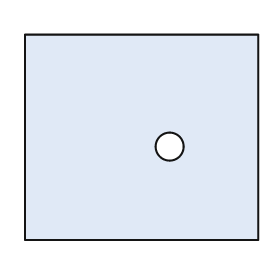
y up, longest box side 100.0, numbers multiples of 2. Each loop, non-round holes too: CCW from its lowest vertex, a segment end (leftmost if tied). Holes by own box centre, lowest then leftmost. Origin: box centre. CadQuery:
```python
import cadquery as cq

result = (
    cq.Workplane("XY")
    .moveTo(-50.0, -44.0)
    .lineTo(50.0, -44.0)
    .lineTo(50.0, 44.0)
    .lineTo(-50.0, 44.0)
    .close()
    .moveTo(12.0, -4.0)
    .circle(6.0)
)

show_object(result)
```